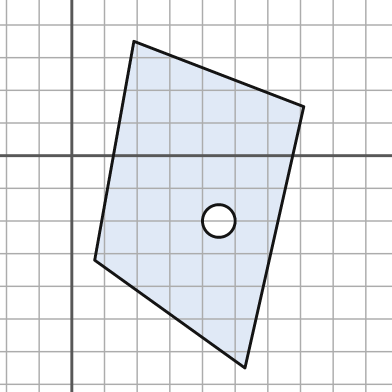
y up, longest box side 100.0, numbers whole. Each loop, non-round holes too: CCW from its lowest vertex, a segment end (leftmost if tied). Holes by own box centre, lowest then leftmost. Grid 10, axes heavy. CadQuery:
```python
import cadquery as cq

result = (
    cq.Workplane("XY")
    .moveTo(53.0, -65.0)
    .lineTo(71.0, 15.0)
    .lineTo(19.0, 35.0)
    .lineTo(7.0, -32.0)
    .close()
    .moveTo(45.0, -20.0)
    .circle(5.0)
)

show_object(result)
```